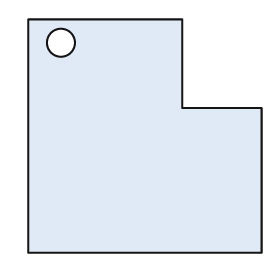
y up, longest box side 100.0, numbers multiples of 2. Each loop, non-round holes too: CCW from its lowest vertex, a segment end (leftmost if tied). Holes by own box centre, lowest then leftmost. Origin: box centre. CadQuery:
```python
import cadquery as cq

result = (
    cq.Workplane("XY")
    .moveTo(-50.0, -50.0)
    .lineTo(50.0, -50.0)
    .lineTo(50.0, 12.0)
    .lineTo(16.0, 12.0)
    .lineTo(16.0, 50.0)
    .lineTo(-50.0, 50.0)
    .close()
    .moveTo(-36.0, 40.0)
    .circle(6.0)
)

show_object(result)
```